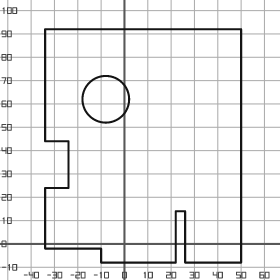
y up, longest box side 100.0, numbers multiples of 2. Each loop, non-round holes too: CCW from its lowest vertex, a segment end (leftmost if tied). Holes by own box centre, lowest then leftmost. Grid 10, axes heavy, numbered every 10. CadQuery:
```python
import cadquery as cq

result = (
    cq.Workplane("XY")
    .moveTo(-10.0, -8.0)
    .lineTo(22.0, -8.0)
    .lineTo(22.0, 14.0)
    .lineTo(26.0, 14.0)
    .lineTo(26.0, -8.0)
    .lineTo(50.0, -8.0)
    .lineTo(50.0, 92.0)
    .lineTo(-34.0, 92.0)
    .lineTo(-34.0, 44.0)
    .lineTo(-24.0, 44.0)
    .lineTo(-24.0, 24.0)
    .lineTo(-34.0, 24.0)
    .lineTo(-34.0, -2.0)
    .lineTo(-10.0, -2.0)
    .close()
    .moveTo(-8.0, 62.0)
    .circle(10.0)
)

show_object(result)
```